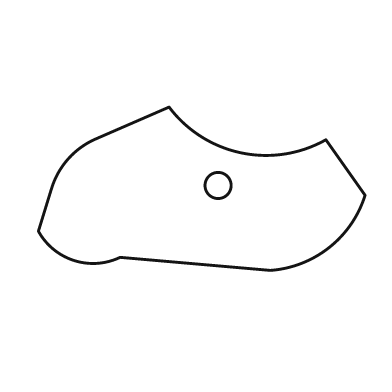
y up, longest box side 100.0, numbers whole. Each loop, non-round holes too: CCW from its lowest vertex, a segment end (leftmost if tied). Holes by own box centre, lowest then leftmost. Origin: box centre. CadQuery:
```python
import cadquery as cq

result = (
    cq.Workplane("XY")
    .moveTo(21.0, -25.0)
    .threePointArc((39.0, -18.0), (50.0, -2.0))
    .lineTo(38.0, 15.0)
    .threePointArc((12.0, 11.0), (-10.0, 25.0))
    .lineTo(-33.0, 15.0)
    .threePointArc((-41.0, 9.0), (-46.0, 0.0))
    .lineTo(-50.0, -13.0)
    .threePointArc((-39.0, -22.0), (-25.0, -21.0))
    .close()
    .moveTo(5.0, 1.0)
    .circle(4.0)
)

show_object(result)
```